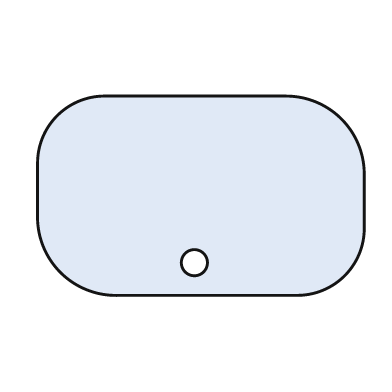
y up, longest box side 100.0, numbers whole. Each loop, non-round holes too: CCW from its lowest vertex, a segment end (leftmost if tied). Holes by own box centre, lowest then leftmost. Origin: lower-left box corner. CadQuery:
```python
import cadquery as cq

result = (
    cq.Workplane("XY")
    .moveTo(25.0, 0.0)
    .lineTo(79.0, 0.0)
    .threePointArc((94.0, 6.0), (100.0, 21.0))
    .lineTo(100.0, 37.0)
    .threePointArc((93.0, 54.0), (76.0, 61.0))
    .lineTo(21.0, 61.0)
    .threePointArc((6.0, 55.0), (0.0, 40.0))
    .lineTo(0.0, 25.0)
    .threePointArc((7.0, 7.0), (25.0, 0.0))
    .close()
    .moveTo(48.0, 10.0)
    .circle(4.0)
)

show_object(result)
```